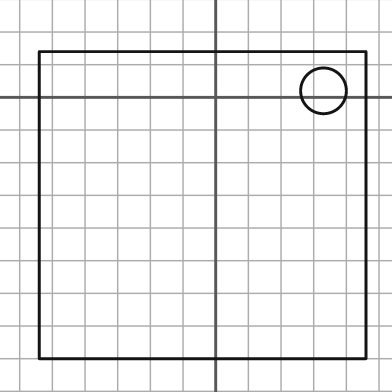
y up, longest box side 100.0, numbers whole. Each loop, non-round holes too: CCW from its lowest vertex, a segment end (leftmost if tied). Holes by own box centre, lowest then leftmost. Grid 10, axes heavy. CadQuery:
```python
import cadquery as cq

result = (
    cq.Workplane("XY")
    .moveTo(-54.0, -80.0)
    .lineTo(46.0, -80.0)
    .lineTo(46.0, 14.0)
    .lineTo(-54.0, 14.0)
    .close()
    .moveTo(33.0, 2.0)
    .circle(7.0)
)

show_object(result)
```